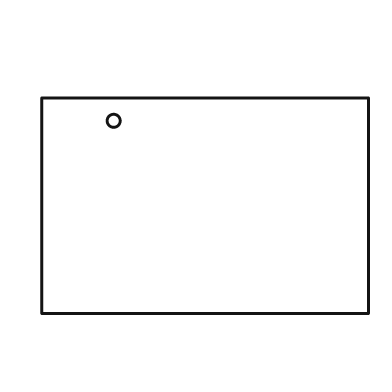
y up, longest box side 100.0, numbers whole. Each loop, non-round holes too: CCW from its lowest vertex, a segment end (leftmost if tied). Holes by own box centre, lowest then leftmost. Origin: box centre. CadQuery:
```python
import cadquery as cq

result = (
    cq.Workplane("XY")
    .moveTo(-50.0, -33.0)
    .lineTo(50.0, -33.0)
    .lineTo(50.0, 33.0)
    .lineTo(-50.0, 33.0)
    .close()
    .moveTo(-28.0, 26.0)
    .circle(2.0)
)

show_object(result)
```